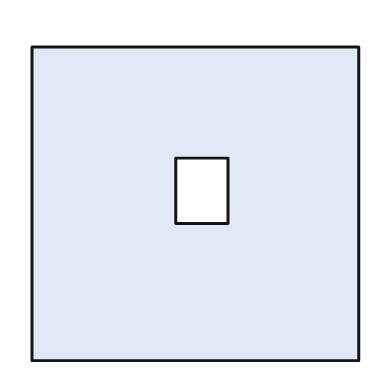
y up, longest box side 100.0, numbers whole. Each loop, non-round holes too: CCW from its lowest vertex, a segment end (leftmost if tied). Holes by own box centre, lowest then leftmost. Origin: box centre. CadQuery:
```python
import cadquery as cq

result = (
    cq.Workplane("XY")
    .moveTo(-50.0, -48.0)
    .lineTo(50.0, -48.0)
    .lineTo(50.0, 48.0)
    .lineTo(-50.0, 48.0)
    .close()
    .moveTo(-6.0, -6.0)
    .lineTo(10.0, -6.0)
    .lineTo(10.0, 14.0)
    .lineTo(-6.0, 14.0)
    .close()
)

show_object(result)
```